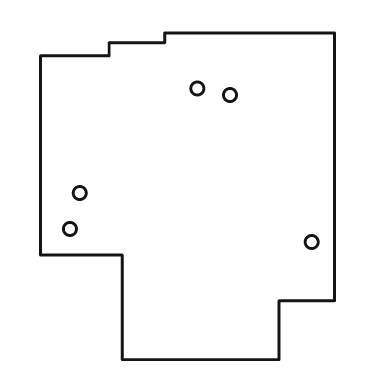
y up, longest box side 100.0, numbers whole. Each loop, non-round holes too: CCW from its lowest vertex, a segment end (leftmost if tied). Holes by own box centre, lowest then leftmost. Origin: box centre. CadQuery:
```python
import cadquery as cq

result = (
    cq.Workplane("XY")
    .moveTo(-20.0, -50.0)
    .lineTo(28.0, -50.0)
    .lineTo(28.0, -32.0)
    .lineTo(45.0, -32.0)
    .lineTo(45.0, 50.0)
    .lineTo(-7.0, 50.0)
    .lineTo(-7.0, 47.0)
    .lineTo(-24.0, 47.0)
    .lineTo(-24.0, 43.0)
    .lineTo(-45.0, 43.0)
    .lineTo(-45.0, -18.0)
    .lineTo(-20.0, -18.0)
    .close()
    .moveTo(38.0, -14.0)
    .circle(2.0)
    .moveTo(-36.0, -10.0)
    .circle(2.0)
    .moveTo(-33.0, 1.0)
    .circle(2.0)
    .moveTo(13.0, 31.0)
    .circle(2.0)
    .moveTo(3.0, 33.0)
    .circle(2.0)
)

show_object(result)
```